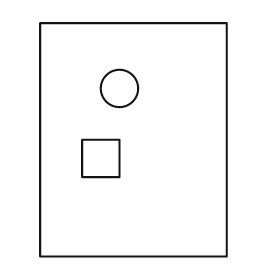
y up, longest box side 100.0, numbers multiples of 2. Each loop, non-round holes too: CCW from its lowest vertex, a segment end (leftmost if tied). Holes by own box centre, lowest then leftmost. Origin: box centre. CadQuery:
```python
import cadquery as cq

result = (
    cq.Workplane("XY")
    .moveTo(-40.0, -50.0)
    .lineTo(40.0, -50.0)
    .lineTo(40.0, 50.0)
    .lineTo(-40.0, 50.0)
    .close()
    .moveTo(-22.0, -16.0)
    .lineTo(-6.0, -16.0)
    .lineTo(-6.0, 0.0)
    .lineTo(-22.0, 0.0)
    .close()
    .moveTo(-6.0, 22.0)
    .circle(8.0)
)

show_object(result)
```